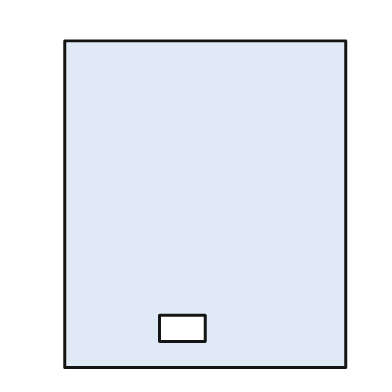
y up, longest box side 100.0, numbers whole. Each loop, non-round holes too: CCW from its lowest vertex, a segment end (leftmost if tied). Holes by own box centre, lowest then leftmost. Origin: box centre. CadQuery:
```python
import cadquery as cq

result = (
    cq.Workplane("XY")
    .moveTo(-43.0, -50.0)
    .lineTo(43.0, -50.0)
    .lineTo(43.0, 50.0)
    .lineTo(-43.0, 50.0)
    .close()
    .moveTo(-14.0, -42.0)
    .lineTo(0.0, -42.0)
    .lineTo(0.0, -34.0)
    .lineTo(-14.0, -34.0)
    .close()
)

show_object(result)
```